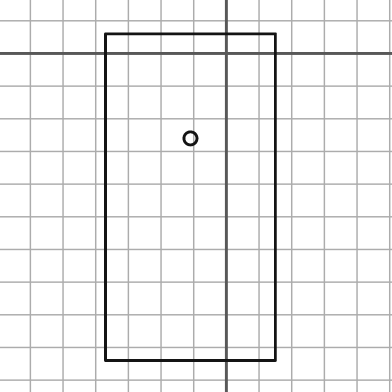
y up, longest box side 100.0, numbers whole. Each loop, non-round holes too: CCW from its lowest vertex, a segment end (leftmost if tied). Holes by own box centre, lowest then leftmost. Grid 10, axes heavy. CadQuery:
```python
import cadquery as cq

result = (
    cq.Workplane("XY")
    .moveTo(-37.0, -94.0)
    .lineTo(15.0, -94.0)
    .lineTo(15.0, 6.0)
    .lineTo(-37.0, 6.0)
    .close()
    .moveTo(-11.0, -26.0)
    .circle(2.0)
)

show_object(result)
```